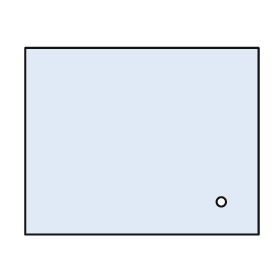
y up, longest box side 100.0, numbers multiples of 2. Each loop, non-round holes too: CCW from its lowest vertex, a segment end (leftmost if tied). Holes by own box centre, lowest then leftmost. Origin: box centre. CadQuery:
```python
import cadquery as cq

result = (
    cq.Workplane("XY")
    .moveTo(-50.0, -40.0)
    .lineTo(50.0, -40.0)
    .lineTo(50.0, 40.0)
    .lineTo(-50.0, 40.0)
    .close()
    .moveTo(34.0, -26.0)
    .circle(2.0)
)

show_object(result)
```